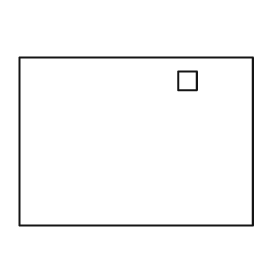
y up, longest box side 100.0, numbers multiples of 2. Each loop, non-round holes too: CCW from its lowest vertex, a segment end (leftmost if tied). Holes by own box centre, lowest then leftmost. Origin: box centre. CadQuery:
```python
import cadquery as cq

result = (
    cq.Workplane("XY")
    .moveTo(-50.0, -36.0)
    .lineTo(50.0, -36.0)
    .lineTo(50.0, 36.0)
    .lineTo(-50.0, 36.0)
    .close()
    .moveTo(18.0, 22.0)
    .lineTo(26.0, 22.0)
    .lineTo(26.0, 30.0)
    .lineTo(18.0, 30.0)
    .close()
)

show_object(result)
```